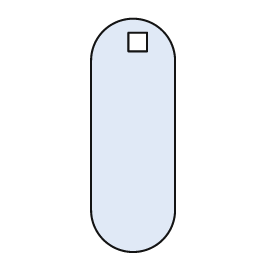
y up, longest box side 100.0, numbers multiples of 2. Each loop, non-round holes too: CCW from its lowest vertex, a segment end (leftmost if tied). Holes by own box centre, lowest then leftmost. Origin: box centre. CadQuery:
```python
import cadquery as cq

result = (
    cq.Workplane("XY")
    .moveTo(-18.0, -32.0)
    .threePointArc((0.0, -50.0), (18.0, -32.0))
    .lineTo(18.0, 32.0)
    .threePointArc((0.0, 50.0), (-18.0, 32.0))
    .close()
    .moveTo(-2.0, 36.0)
    .lineTo(6.0, 36.0)
    .lineTo(6.0, 44.0)
    .lineTo(-2.0, 44.0)
    .close()
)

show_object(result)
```